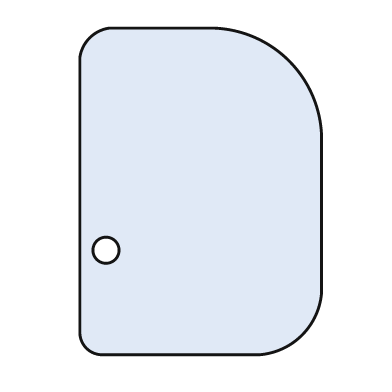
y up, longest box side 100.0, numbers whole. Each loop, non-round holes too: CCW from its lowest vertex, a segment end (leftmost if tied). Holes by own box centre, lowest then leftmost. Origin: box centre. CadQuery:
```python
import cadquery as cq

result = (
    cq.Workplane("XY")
    .moveTo(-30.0, -50.0)
    .lineTo(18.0, -50.0)
    .threePointArc((31.0, -44.0), (37.0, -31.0))
    .lineTo(37.0, 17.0)
    .threePointArc((27.0, 40.0), (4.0, 50.0))
    .lineTo(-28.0, 50.0)
    .threePointArc((-34.0, 47.0), (-37.0, 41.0))
    .lineTo(-37.0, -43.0)
    .threePointArc((-35.0, -48.0), (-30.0, -50.0))
    .close()
    .moveTo(-29.0, -18.0)
    .circle(4.0)
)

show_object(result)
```